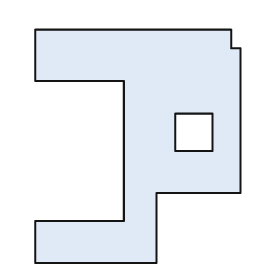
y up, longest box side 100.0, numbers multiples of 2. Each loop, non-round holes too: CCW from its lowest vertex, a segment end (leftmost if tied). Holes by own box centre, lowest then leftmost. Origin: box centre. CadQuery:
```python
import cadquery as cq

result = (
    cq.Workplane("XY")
    .moveTo(-44.0, -50.0)
    .lineTo(8.0, -50.0)
    .lineTo(8.0, -20.0)
    .lineTo(44.0, -20.0)
    .lineTo(44.0, 42.0)
    .lineTo(40.0, 42.0)
    .lineTo(40.0, 50.0)
    .lineTo(-44.0, 50.0)
    .lineTo(-44.0, 28.0)
    .lineTo(-6.0, 28.0)
    .lineTo(-6.0, -32.0)
    .lineTo(-44.0, -32.0)
    .close()
    .moveTo(16.0, -2.0)
    .lineTo(32.0, -2.0)
    .lineTo(32.0, 14.0)
    .lineTo(16.0, 14.0)
    .close()
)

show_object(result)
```